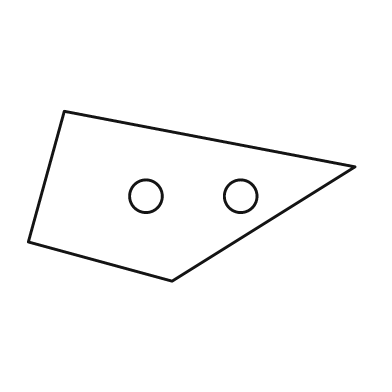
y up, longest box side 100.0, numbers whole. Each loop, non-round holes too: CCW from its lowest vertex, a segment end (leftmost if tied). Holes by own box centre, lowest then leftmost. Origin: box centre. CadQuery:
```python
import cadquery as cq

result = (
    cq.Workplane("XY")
    .moveTo(-6.0, -26.0)
    .lineTo(50.0, 9.0)
    .lineTo(-39.0, 26.0)
    .lineTo(-50.0, -14.0)
    .close()
    .moveTo(-14.0, 0.0)
    .circle(5.0)
    .moveTo(15.0, 0.0)
    .circle(5.0)
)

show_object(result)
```